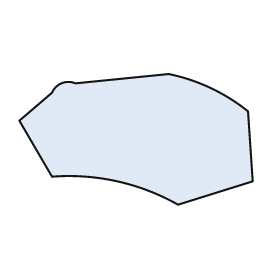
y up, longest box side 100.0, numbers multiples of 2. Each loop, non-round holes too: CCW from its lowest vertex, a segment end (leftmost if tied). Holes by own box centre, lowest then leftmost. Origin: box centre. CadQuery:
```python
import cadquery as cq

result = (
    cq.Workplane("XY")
    .moveTo(18.0, -28.0)
    .lineTo(50.0, -18.0)
    .lineTo(48.0, 12.0)
    .threePointArc((32.0, 22.0), (14.0, 28.0))
    .lineTo(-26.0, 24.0)
    .threePointArc((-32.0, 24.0), (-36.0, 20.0))
    .lineTo(-50.0, 8.0)
    .lineTo(-36.0, -16.0)
    .threePointArc((-8.0, -18.0), (18.0, -28.0))
    .close()
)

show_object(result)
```